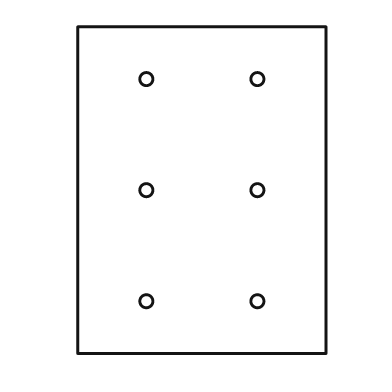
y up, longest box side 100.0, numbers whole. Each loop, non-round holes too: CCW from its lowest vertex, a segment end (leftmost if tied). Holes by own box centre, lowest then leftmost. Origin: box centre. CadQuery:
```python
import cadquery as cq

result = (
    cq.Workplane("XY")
    .moveTo(-38.0, -50.0)
    .lineTo(38.0, -50.0)
    .lineTo(38.0, 50.0)
    .lineTo(-38.0, 50.0)
    .close()
    .moveTo(-17.0, -34.0)
    .circle(2.0)
    .moveTo(17.0, -34.0)
    .circle(2.0)
    .moveTo(-17.0, 0.0)
    .circle(2.0)
    .moveTo(17.0, 0.0)
    .circle(2.0)
    .moveTo(-17.0, 34.0)
    .circle(2.0)
    .moveTo(17.0, 34.0)
    .circle(2.0)
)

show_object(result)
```